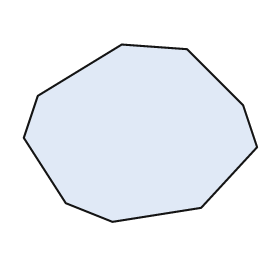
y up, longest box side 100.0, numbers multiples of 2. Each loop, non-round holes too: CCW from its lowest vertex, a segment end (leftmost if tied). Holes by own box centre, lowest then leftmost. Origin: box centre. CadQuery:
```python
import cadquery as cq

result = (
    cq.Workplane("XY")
    .moveTo(-12.0, -38.0)
    .lineTo(26.0, -32.0)
    .lineTo(50.0, -6.0)
    .lineTo(44.0, 12.0)
    .lineTo(20.0, 36.0)
    .lineTo(-8.0, 38.0)
    .lineTo(-44.0, 16.0)
    .lineTo(-50.0, -2.0)
    .lineTo(-32.0, -30.0)
    .close()
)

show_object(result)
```